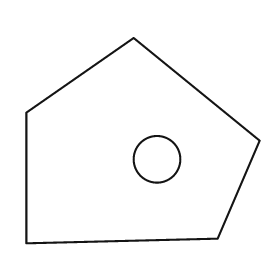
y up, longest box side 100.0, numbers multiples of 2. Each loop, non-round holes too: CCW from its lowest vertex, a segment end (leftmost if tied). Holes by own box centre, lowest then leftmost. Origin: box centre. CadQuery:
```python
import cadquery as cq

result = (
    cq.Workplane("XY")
    .moveTo(-50.0, -44.0)
    .lineTo(32.0, -42.0)
    .lineTo(50.0, 0.0)
    .lineTo(-4.0, 44.0)
    .lineTo(-50.0, 12.0)
    .close()
    .moveTo(6.0, -8.0)
    .circle(10.0)
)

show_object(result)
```